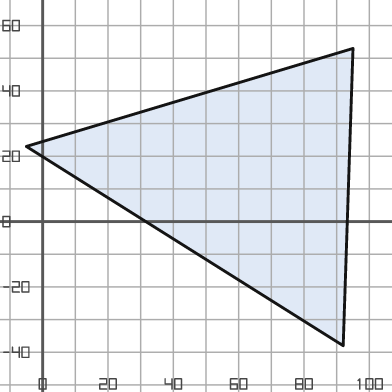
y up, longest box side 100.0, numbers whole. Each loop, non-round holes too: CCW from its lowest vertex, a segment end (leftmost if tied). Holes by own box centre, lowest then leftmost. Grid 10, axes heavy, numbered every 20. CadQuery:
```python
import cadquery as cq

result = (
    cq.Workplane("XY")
    .moveTo(92.0, -38.0)
    .lineTo(95.0, 53.0)
    .lineTo(-5.0, 23.0)
    .close()
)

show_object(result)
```